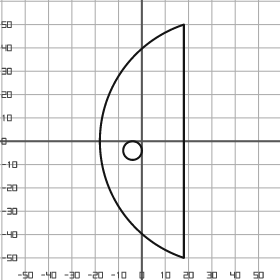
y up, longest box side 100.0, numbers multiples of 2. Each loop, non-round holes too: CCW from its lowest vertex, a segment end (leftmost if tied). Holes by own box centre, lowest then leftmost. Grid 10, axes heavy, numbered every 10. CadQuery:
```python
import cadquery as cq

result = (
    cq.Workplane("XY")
    .moveTo(18.0, -50.0)
    .lineTo(18.0, 50.0)
    .threePointArc((-18.0, 0.0), (18.0, -50.0))
    .close()
    .moveTo(-4.0, -4.0)
    .circle(4.0)
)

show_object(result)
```